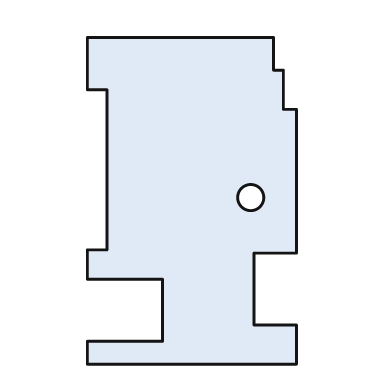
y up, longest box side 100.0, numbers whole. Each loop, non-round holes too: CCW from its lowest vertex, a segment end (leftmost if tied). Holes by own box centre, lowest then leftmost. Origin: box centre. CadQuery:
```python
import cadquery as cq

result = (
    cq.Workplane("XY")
    .moveTo(-32.0, -50.0)
    .lineTo(32.0, -50.0)
    .lineTo(32.0, -38.0)
    .lineTo(19.0, -38.0)
    .lineTo(19.0, -16.0)
    .lineTo(32.0, -16.0)
    .lineTo(32.0, 28.0)
    .lineTo(28.0, 28.0)
    .lineTo(28.0, 40.0)
    .lineTo(25.0, 40.0)
    .lineTo(25.0, 50.0)
    .lineTo(-32.0, 50.0)
    .lineTo(-32.0, 34.0)
    .lineTo(-26.0, 34.0)
    .lineTo(-26.0, -15.0)
    .lineTo(-32.0, -15.0)
    .lineTo(-32.0, -24.0)
    .lineTo(-9.0, -24.0)
    .lineTo(-9.0, -43.0)
    .lineTo(-32.0, -43.0)
    .close()
    .moveTo(18.0, 1.0)
    .circle(4.0)
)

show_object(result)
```